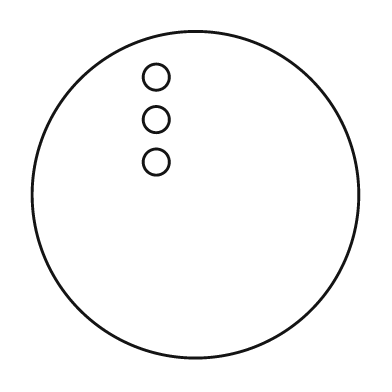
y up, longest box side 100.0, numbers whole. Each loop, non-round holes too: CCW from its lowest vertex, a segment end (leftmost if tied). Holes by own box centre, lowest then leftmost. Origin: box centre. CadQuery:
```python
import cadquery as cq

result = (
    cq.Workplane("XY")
    .moveTo(0.0, 0.0)
    .circle(50.0)
    .moveTo(-12.0, 10.0)
    .circle(4.0)
    .moveTo(-12.0, 23.0)
    .circle(4.0)
    .moveTo(-12.0, 36.0)
    .circle(4.0)
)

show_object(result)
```